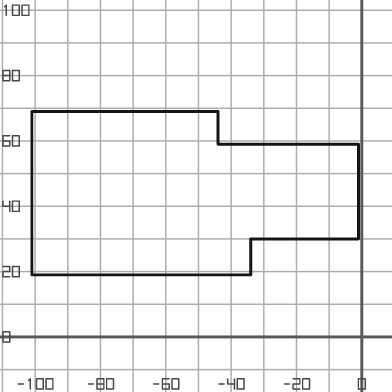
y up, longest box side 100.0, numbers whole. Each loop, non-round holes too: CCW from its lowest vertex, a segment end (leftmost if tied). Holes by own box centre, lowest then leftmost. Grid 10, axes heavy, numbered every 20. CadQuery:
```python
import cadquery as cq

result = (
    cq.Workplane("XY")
    .moveTo(-101.0, 19.0)
    .lineTo(-34.0, 19.0)
    .lineTo(-34.0, 30.0)
    .lineTo(-1.0, 30.0)
    .lineTo(-1.0, 59.0)
    .lineTo(-44.0, 59.0)
    .lineTo(-44.0, 69.0)
    .lineTo(-101.0, 69.0)
    .close()
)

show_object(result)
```